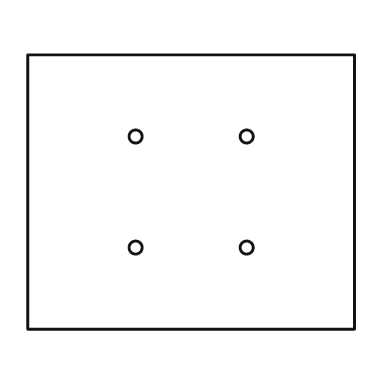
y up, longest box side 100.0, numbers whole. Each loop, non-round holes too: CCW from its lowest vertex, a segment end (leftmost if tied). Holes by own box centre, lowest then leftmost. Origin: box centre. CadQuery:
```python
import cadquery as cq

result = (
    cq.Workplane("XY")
    .moveTo(-50.0, -42.0)
    .lineTo(50.0, -42.0)
    .lineTo(50.0, 42.0)
    .lineTo(-50.0, 42.0)
    .close()
    .moveTo(-17.0, -17.0)
    .circle(2.0)
    .moveTo(17.0, -17.0)
    .circle(2.0)
    .moveTo(-17.0, 17.0)
    .circle(2.0)
    .moveTo(17.0, 17.0)
    .circle(2.0)
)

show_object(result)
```